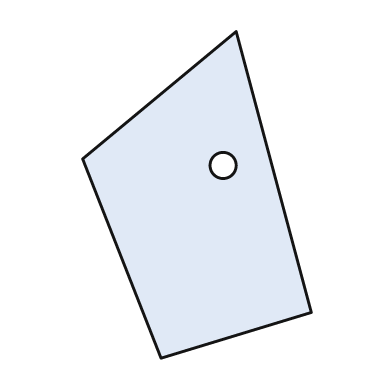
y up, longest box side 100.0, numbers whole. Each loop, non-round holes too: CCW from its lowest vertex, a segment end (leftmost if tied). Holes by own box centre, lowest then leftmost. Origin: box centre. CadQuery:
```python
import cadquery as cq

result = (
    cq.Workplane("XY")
    .moveTo(-11.0, -50.0)
    .lineTo(35.0, -36.0)
    .lineTo(12.0, 50.0)
    .lineTo(-35.0, 11.0)
    .close()
    .moveTo(8.0, 9.0)
    .circle(4.0)
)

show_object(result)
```